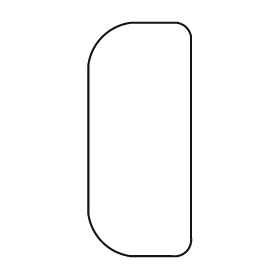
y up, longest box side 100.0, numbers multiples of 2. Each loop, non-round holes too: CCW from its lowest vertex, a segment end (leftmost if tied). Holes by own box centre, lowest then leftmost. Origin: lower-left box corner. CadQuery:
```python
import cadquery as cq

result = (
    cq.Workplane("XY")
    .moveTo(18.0, 0.0)
    .lineTo(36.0, 0.0)
    .threePointArc((42.0, 2.0), (44.0, 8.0))
    .lineTo(44.0, 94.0)
    .threePointArc((42.0, 98.0), (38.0, 100.0))
    .lineTo(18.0, 100.0)
    .threePointArc((6.0, 94.0), (0.0, 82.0))
    .lineTo(0.0, 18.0)
    .threePointArc((6.0, 6.0), (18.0, 0.0))
    .close()
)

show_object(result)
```